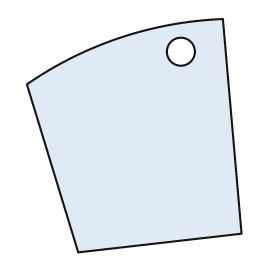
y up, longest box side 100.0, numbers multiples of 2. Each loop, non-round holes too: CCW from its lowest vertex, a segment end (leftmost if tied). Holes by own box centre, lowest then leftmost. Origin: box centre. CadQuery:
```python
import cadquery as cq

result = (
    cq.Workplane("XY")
    .moveTo(-24.0, -50.0)
    .lineTo(46.0, -42.0)
    .lineTo(38.0, 50.0)
    .threePointArc((-6.0, 42.0), (-46.0, 22.0))
    .close()
    .moveTo(20.0, 36.0)
    .circle(6.0)
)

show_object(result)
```